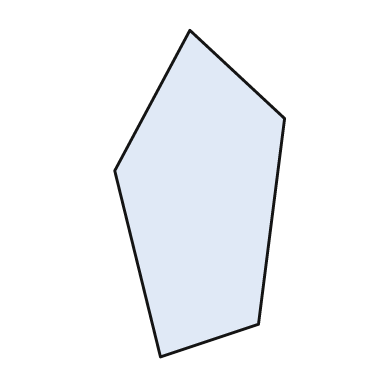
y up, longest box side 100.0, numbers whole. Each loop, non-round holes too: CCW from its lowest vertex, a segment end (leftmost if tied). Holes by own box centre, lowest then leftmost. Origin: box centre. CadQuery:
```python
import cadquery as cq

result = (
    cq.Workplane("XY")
    .moveTo(-12.0, -50.0)
    .lineTo(18.0, -40.0)
    .lineTo(26.0, 23.0)
    .lineTo(-3.0, 50.0)
    .lineTo(-26.0, 7.0)
    .close()
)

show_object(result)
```